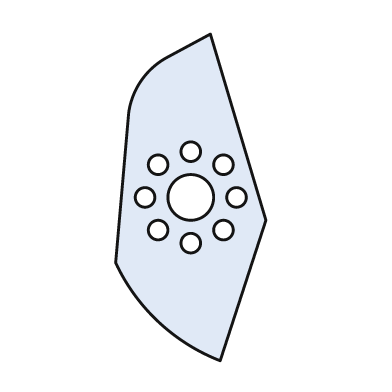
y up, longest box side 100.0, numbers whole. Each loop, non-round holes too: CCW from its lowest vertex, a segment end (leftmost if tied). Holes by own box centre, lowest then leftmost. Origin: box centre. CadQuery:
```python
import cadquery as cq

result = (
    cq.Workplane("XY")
    .moveTo(9.0, -50.0)
    .lineTo(23.0, -7.0)
    .lineTo(6.0, 50.0)
    .lineTo(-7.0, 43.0)
    .threePointArc((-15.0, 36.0), (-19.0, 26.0))
    .lineTo(-23.0, -20.0)
    .threePointArc((-10.0, -38.0), (9.0, -50.0))
    .close()
    .moveTo(0.0, -14.0)
    .circle(3.0)
    .moveTo(-10.0, -10.0)
    .circle(3.0)
    .moveTo(10.0, -10.0)
    .circle(3.0)
    .moveTo(-14.0, 0.0)
    .circle(3.0)
    .moveTo(0.0, 0.0)
    .circle(7.0)
    .moveTo(14.0, 0.0)
    .circle(3.0)
    .moveTo(-10.0, 10.0)
    .circle(3.0)
    .moveTo(10.0, 10.0)
    .circle(3.0)
    .moveTo(0.0, 14.0)
    .circle(3.0)
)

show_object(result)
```